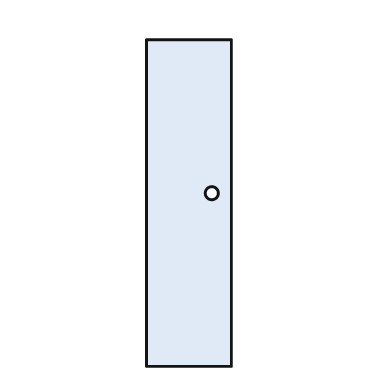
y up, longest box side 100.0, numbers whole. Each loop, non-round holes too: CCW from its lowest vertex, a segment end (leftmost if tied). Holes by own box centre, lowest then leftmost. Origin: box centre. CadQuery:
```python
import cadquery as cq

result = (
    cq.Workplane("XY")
    .moveTo(-13.0, -50.0)
    .lineTo(13.0, -50.0)
    .lineTo(13.0, 50.0)
    .lineTo(-13.0, 50.0)
    .close()
    .moveTo(7.0, 3.0)
    .circle(2.0)
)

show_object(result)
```